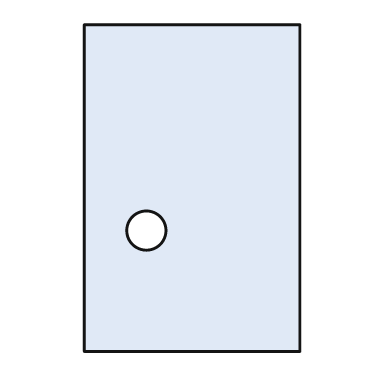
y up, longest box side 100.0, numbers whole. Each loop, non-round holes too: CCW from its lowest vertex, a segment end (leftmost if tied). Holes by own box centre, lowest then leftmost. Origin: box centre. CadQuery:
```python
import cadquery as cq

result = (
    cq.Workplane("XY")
    .moveTo(-33.0, -50.0)
    .lineTo(33.0, -50.0)
    .lineTo(33.0, 50.0)
    .lineTo(-33.0, 50.0)
    .close()
    .moveTo(-14.0, -13.0)
    .circle(6.0)
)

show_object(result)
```